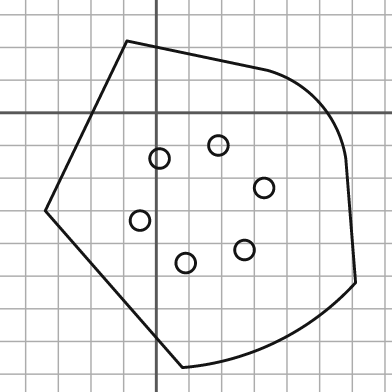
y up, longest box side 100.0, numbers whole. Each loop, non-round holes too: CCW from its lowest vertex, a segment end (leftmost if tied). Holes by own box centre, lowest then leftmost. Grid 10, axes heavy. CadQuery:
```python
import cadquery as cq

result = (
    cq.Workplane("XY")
    .moveTo(8.0, -78.0)
    .threePointArc((37.0, -70.0), (61.0, -52.0))
    .lineTo(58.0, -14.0)
    .threePointArc((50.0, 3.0), (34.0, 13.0))
    .lineTo(-9.0, 22.0)
    .lineTo(-34.0, -30.0)
    .close()
    .moveTo(9.0, -46.0)
    .circle(3.0)
    .moveTo(27.0, -42.0)
    .circle(3.0)
    .moveTo(-5.0, -33.0)
    .circle(3.0)
    .moveTo(33.0, -23.0)
    .circle(3.0)
    .moveTo(1.0, -14.0)
    .circle(3.0)
    .moveTo(19.0, -10.0)
    .circle(3.0)
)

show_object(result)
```